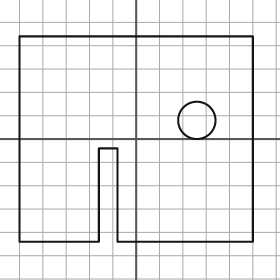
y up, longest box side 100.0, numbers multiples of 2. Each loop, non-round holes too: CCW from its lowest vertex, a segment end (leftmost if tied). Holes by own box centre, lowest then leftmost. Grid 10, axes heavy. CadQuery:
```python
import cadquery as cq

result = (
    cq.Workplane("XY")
    .moveTo(-50.0, -44.0)
    .lineTo(-16.0, -44.0)
    .lineTo(-16.0, -4.0)
    .lineTo(-8.0, -4.0)
    .lineTo(-8.0, -44.0)
    .lineTo(50.0, -44.0)
    .lineTo(50.0, 44.0)
    .lineTo(-50.0, 44.0)
    .close()
    .moveTo(26.0, 8.0)
    .circle(8.0)
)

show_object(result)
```